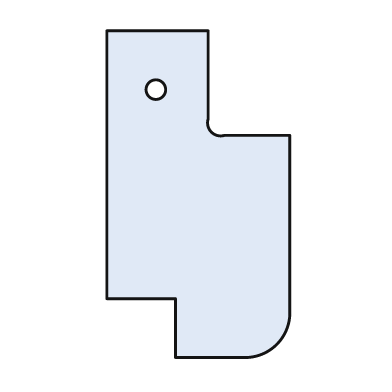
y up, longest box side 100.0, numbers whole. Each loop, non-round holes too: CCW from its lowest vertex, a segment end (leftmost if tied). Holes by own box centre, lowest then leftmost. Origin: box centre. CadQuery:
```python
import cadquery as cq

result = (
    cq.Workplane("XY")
    .moveTo(-7.0, -50.0)
    .lineTo(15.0, -50.0)
    .threePointArc((24.0, -46.0), (28.0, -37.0))
    .lineTo(28.0, 18.0)
    .lineTo(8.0, 18.0)
    .threePointArc((4.0, 19.0), (3.0, 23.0))
    .lineTo(3.0, 50.0)
    .lineTo(-28.0, 50.0)
    .lineTo(-28.0, -32.0)
    .lineTo(-7.0, -32.0)
    .close()
    .moveTo(-13.0, 32.0)
    .circle(3.0)
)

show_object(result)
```